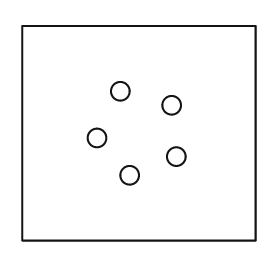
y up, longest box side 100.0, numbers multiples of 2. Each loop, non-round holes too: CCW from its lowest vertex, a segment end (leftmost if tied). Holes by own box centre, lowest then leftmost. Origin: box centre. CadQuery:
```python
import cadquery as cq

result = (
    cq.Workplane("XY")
    .moveTo(-50.0, -46.0)
    .lineTo(50.0, -46.0)
    .lineTo(50.0, 46.0)
    .lineTo(-50.0, 46.0)
    .close()
    .moveTo(-4.0, -18.0)
    .circle(4.0)
    .moveTo(16.0, -10.0)
    .circle(4.0)
    .moveTo(-18.0, -2.0)
    .circle(4.0)
    .moveTo(14.0, 12.0)
    .circle(4.0)
    .moveTo(-8.0, 18.0)
    .circle(4.0)
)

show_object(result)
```